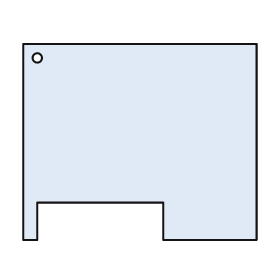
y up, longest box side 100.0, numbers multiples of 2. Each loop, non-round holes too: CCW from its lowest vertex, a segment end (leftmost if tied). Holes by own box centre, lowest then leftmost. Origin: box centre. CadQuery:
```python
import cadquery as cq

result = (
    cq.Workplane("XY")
    .moveTo(-50.0, -42.0)
    .lineTo(-44.0, -42.0)
    .lineTo(-44.0, -26.0)
    .lineTo(10.0, -26.0)
    .lineTo(10.0, -42.0)
    .lineTo(50.0, -42.0)
    .lineTo(50.0, 42.0)
    .lineTo(-50.0, 42.0)
    .close()
    .moveTo(-44.0, 36.0)
    .circle(2.0)
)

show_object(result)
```